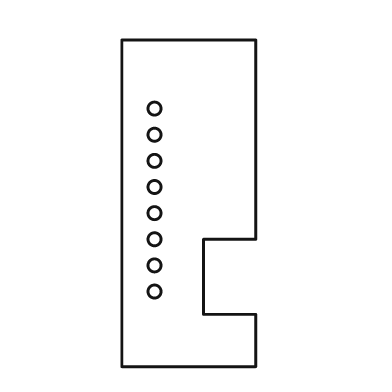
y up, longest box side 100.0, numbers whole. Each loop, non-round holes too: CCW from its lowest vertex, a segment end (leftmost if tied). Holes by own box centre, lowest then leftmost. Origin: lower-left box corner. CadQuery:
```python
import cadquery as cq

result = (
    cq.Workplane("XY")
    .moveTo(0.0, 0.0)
    .lineTo(41.0, 0.0)
    .lineTo(41.0, 16.0)
    .lineTo(25.0, 16.0)
    .lineTo(25.0, 39.0)
    .lineTo(41.0, 39.0)
    .lineTo(41.0, 100.0)
    .lineTo(0.0, 100.0)
    .close()
    .moveTo(10.0, 23.0)
    .circle(2.0)
    .moveTo(10.0, 31.0)
    .circle(2.0)
    .moveTo(10.0, 39.0)
    .circle(2.0)
    .moveTo(10.0, 47.0)
    .circle(2.0)
    .moveTo(10.0, 55.0)
    .circle(2.0)
    .moveTo(10.0, 63.0)
    .circle(2.0)
    .moveTo(10.0, 71.0)
    .circle(2.0)
    .moveTo(10.0, 79.0)
    .circle(2.0)
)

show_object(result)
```